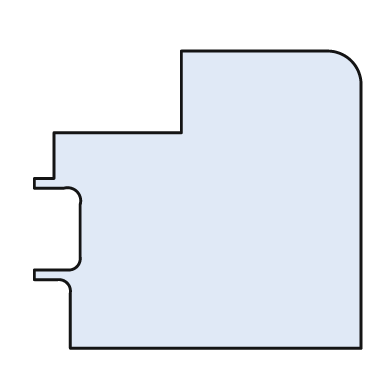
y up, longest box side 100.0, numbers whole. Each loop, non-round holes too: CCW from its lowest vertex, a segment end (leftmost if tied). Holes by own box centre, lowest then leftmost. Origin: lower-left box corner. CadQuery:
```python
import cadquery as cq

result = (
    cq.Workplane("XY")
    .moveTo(11.0, 0.0)
    .lineTo(100.0, 0.0)
    .lineTo(100.0, 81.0)
    .threePointArc((97.0, 88.0), (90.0, 91.0))
    .lineTo(45.0, 91.0)
    .lineTo(45.0, 66.0)
    .lineTo(6.0, 66.0)
    .lineTo(6.0, 52.0)
    .lineTo(0.0, 52.0)
    .lineTo(0.0, 49.0)
    .lineTo(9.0, 49.0)
    .threePointArc((13.0, 48.0), (14.0, 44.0))
    .lineTo(14.0, 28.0)
    .threePointArc((13.0, 25.0), (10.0, 24.0))
    .lineTo(0.0, 24.0)
    .lineTo(0.0, 21.0)
    .lineTo(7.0, 21.0)
    .threePointArc((10.0, 20.0), (11.0, 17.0))
    .close()
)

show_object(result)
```